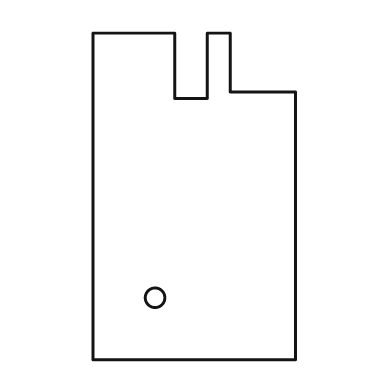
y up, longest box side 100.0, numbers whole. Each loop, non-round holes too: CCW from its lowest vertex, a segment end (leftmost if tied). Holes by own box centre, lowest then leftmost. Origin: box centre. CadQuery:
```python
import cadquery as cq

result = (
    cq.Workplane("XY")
    .moveTo(-31.0, -50.0)
    .lineTo(31.0, -50.0)
    .lineTo(31.0, 32.0)
    .lineTo(11.0, 32.0)
    .lineTo(11.0, 50.0)
    .lineTo(4.0, 50.0)
    .lineTo(4.0, 30.0)
    .lineTo(-6.0, 30.0)
    .lineTo(-6.0, 50.0)
    .lineTo(-31.0, 50.0)
    .close()
    .moveTo(-12.0, -31.0)
    .circle(3.0)
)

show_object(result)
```